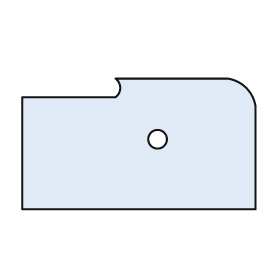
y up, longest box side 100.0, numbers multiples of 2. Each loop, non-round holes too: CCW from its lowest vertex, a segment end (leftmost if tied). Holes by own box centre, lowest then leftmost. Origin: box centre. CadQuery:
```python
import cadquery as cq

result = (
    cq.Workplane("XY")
    .moveTo(-50.0, -28.0)
    .lineTo(50.0, -28.0)
    .lineTo(50.0, 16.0)
    .threePointArc((46.0, 24.0), (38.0, 28.0))
    .lineTo(-10.0, 28.0)
    .threePointArc((-8.0, 24.0), (-10.0, 20.0))
    .lineTo(-50.0, 20.0)
    .close()
    .moveTo(8.0, 2.0)
    .circle(4.0)
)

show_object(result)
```